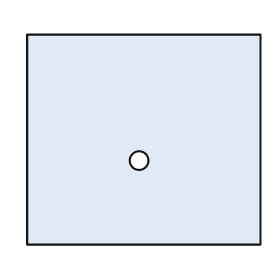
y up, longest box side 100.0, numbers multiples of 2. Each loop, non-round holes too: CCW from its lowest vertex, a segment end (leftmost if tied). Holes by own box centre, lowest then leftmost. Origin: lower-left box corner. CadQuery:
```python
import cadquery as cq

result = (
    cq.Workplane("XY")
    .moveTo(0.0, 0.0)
    .lineTo(100.0, 0.0)
    .lineTo(100.0, 90.0)
    .lineTo(0.0, 90.0)
    .close()
    .moveTo(48.0, 36.0)
    .circle(4.0)
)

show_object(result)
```